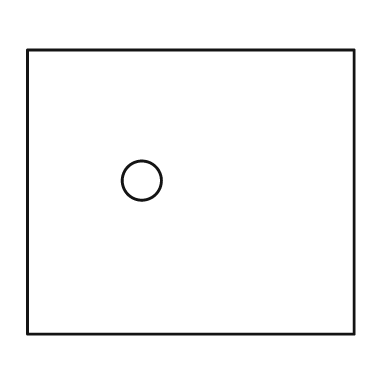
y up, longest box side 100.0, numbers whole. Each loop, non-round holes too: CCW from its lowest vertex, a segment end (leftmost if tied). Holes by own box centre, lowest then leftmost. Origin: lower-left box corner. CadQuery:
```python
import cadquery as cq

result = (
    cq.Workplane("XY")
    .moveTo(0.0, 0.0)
    .lineTo(100.0, 0.0)
    .lineTo(100.0, 87.0)
    .lineTo(0.0, 87.0)
    .close()
    .moveTo(35.0, 47.0)
    .circle(6.0)
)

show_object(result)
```